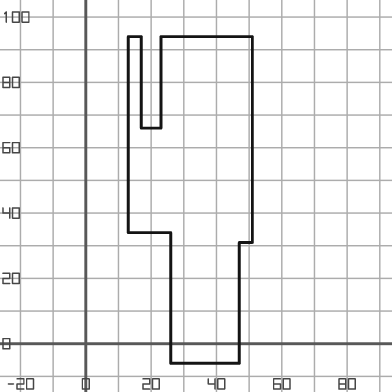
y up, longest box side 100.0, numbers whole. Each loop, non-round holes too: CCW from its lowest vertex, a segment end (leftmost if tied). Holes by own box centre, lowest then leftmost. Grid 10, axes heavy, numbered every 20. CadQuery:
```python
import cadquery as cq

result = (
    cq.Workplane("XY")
    .moveTo(26.0, -6.0)
    .lineTo(47.0, -6.0)
    .lineTo(47.0, 31.0)
    .lineTo(51.0, 31.0)
    .lineTo(51.0, 94.0)
    .lineTo(23.0, 94.0)
    .lineTo(23.0, 66.0)
    .lineTo(17.0, 66.0)
    .lineTo(17.0, 94.0)
    .lineTo(13.0, 94.0)
    .lineTo(13.0, 34.0)
    .lineTo(26.0, 34.0)
    .close()
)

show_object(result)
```